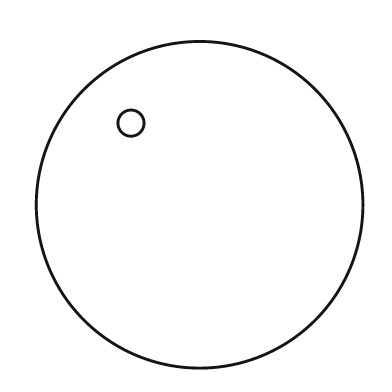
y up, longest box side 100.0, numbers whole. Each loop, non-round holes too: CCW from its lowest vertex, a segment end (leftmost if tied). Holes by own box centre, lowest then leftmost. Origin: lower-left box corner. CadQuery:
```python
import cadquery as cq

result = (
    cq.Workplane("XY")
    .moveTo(50.0, 50.0)
    .circle(50.0)
    .moveTo(29.0, 75.0)
    .circle(4.0)
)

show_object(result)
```